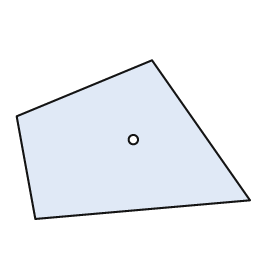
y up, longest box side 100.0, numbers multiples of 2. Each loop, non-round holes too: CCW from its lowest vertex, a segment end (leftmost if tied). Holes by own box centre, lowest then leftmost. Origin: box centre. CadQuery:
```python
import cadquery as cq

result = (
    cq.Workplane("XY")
    .moveTo(-42.0, -34.0)
    .lineTo(50.0, -26.0)
    .lineTo(8.0, 34.0)
    .lineTo(-50.0, 10.0)
    .close()
    .moveTo(0.0, 0.0)
    .circle(2.0)
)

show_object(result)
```